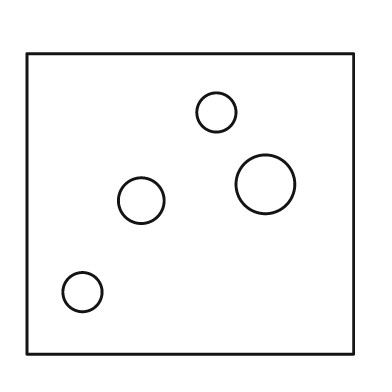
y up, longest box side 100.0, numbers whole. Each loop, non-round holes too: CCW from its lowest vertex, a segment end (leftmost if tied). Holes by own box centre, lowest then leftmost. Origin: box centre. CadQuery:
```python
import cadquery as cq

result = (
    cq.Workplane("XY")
    .moveTo(-50.0, -46.0)
    .lineTo(50.0, -46.0)
    .lineTo(50.0, 46.0)
    .lineTo(-50.0, 46.0)
    .close()
    .moveTo(-33.0, -27.0)
    .circle(6.0)
    .moveTo(-15.0, 1.0)
    .circle(7.0)
    .moveTo(23.0, 6.0)
    .circle(9.0)
    .moveTo(8.0, 28.0)
    .circle(6.0)
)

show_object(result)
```